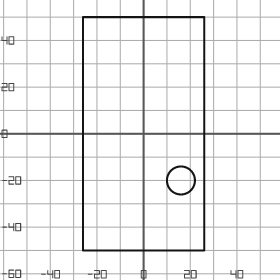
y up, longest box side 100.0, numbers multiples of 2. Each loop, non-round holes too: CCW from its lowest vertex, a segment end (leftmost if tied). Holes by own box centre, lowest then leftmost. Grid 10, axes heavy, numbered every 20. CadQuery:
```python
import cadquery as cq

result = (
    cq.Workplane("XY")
    .moveTo(-26.0, -50.0)
    .lineTo(26.0, -50.0)
    .lineTo(26.0, 50.0)
    .lineTo(-26.0, 50.0)
    .close()
    .moveTo(16.0, -20.0)
    .circle(6.0)
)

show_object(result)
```